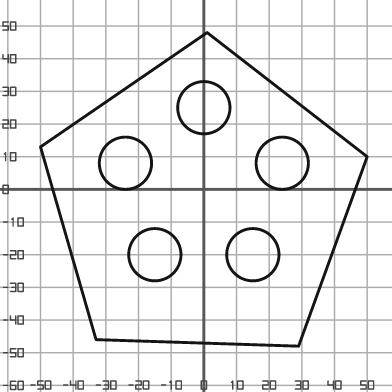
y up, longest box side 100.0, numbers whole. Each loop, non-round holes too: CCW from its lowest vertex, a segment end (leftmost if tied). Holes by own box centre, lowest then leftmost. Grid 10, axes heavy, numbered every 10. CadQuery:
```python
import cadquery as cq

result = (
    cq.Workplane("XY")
    .moveTo(29.0, -48.0)
    .lineTo(50.0, 10.0)
    .lineTo(1.0, 48.0)
    .lineTo(-50.0, 13.0)
    .lineTo(-33.0, -46.0)
    .close()
    .moveTo(-15.0, -20.0)
    .circle(8.0)
    .moveTo(15.0, -20.0)
    .circle(8.0)
    .moveTo(-24.0, 8.0)
    .circle(8.0)
    .moveTo(24.0, 8.0)
    .circle(8.0)
    .moveTo(0.0, 25.0)
    .circle(8.0)
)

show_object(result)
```